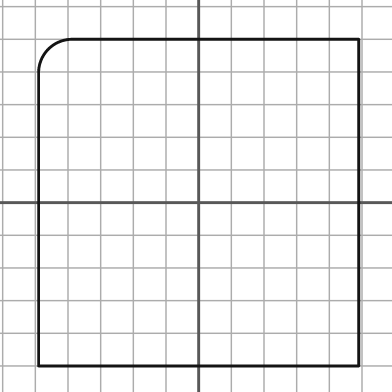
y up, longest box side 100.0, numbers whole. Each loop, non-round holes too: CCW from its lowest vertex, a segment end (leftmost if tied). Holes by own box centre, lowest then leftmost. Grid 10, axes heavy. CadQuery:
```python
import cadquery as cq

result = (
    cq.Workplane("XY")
    .moveTo(-49.0, -50.0)
    .lineTo(49.0, -50.0)
    .lineTo(49.0, 50.0)
    .lineTo(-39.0, 50.0)
    .threePointArc((-46.0, 47.0), (-49.0, 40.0))
    .close()
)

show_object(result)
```